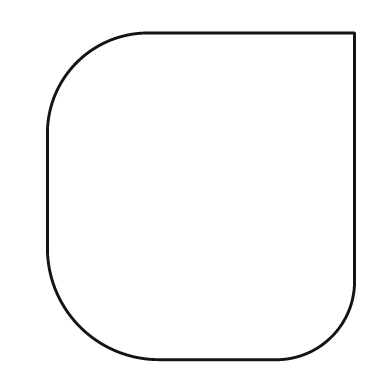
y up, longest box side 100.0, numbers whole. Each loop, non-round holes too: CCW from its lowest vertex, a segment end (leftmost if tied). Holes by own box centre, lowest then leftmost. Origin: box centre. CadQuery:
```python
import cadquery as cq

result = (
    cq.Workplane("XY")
    .moveTo(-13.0, -50.0)
    .lineTo(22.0, -50.0)
    .threePointArc((40.0, -43.0), (47.0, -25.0))
    .lineTo(47.0, 50.0)
    .lineTo(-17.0, 50.0)
    .threePointArc((-38.0, 41.0), (-47.0, 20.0))
    .lineTo(-47.0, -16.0)
    .threePointArc((-37.0, -40.0), (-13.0, -50.0))
    .close()
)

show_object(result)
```